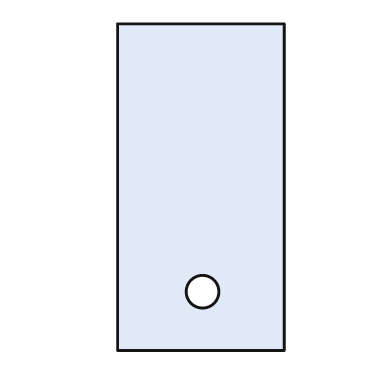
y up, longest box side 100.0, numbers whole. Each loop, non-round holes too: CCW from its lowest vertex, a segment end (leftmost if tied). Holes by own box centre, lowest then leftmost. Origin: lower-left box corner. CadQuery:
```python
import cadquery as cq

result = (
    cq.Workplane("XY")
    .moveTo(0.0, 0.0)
    .lineTo(51.0, 0.0)
    .lineTo(51.0, 100.0)
    .lineTo(0.0, 100.0)
    .close()
    .moveTo(26.0, 18.0)
    .circle(5.0)
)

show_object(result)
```